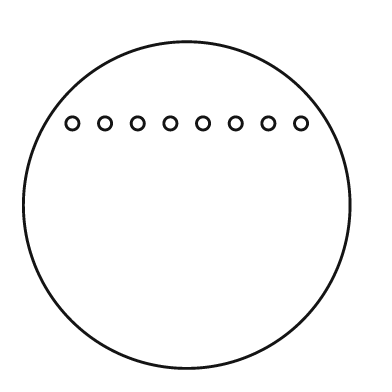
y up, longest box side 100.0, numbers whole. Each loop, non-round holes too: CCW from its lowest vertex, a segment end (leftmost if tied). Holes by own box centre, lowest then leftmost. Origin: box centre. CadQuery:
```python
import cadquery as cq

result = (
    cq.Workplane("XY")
    .moveTo(0.0, 0.0)
    .circle(50.0)
    .moveTo(-35.0, 25.0)
    .circle(2.0)
    .moveTo(-25.0, 25.0)
    .circle(2.0)
    .moveTo(-15.0, 25.0)
    .circle(2.0)
    .moveTo(-5.0, 25.0)
    .circle(2.0)
    .moveTo(5.0, 25.0)
    .circle(2.0)
    .moveTo(15.0, 25.0)
    .circle(2.0)
    .moveTo(25.0, 25.0)
    .circle(2.0)
    .moveTo(35.0, 25.0)
    .circle(2.0)
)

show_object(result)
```